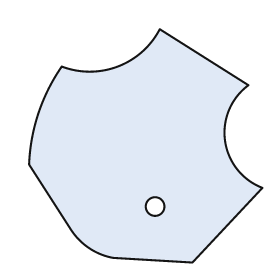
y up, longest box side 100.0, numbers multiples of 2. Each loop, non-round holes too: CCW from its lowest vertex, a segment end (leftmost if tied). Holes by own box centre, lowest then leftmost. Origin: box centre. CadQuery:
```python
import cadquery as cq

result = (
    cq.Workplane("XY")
    .moveTo(20.0, -50.0)
    .lineTo(50.0, -18.0)
    .threePointArc((34.0, 2.0), (44.0, 26.0))
    .lineTo(6.0, 50.0)
    .threePointArc((-12.0, 34.0), (-36.0, 34.0))
    .threePointArc((-46.0, 14.0), (-50.0, -8.0))
    .lineTo(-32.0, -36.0)
    .threePointArc((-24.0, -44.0), (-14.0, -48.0))
    .close()
    .moveTo(4.0, -26.0)
    .circle(4.0)
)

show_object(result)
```